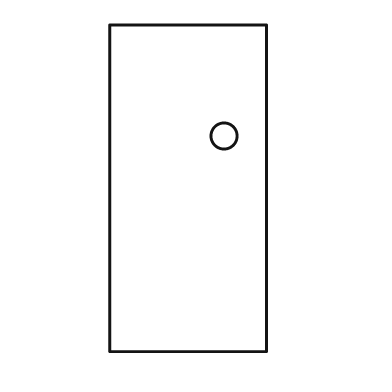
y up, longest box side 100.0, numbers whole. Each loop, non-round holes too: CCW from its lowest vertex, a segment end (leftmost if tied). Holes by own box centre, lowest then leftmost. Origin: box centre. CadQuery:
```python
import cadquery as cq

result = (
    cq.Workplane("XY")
    .moveTo(-24.0, -50.0)
    .lineTo(24.0, -50.0)
    .lineTo(24.0, 50.0)
    .lineTo(-24.0, 50.0)
    .close()
    .moveTo(11.0, 16.0)
    .circle(4.0)
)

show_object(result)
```